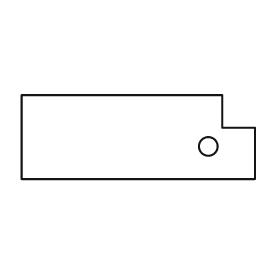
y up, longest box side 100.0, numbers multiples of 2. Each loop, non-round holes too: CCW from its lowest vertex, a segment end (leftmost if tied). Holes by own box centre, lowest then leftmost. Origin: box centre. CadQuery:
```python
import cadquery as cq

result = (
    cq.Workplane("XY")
    .moveTo(-50.0, -18.0)
    .lineTo(50.0, -18.0)
    .lineTo(50.0, 4.0)
    .lineTo(36.0, 4.0)
    .lineTo(36.0, 18.0)
    .lineTo(-50.0, 18.0)
    .close()
    .moveTo(30.0, -4.0)
    .circle(4.0)
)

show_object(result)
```